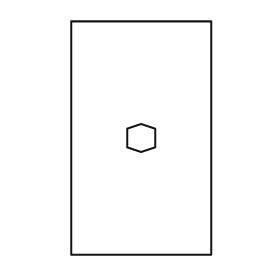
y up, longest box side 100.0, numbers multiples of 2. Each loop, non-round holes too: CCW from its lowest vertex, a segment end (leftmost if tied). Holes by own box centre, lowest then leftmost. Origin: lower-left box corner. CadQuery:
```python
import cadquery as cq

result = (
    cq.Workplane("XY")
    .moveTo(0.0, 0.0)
    .lineTo(60.0, 0.0)
    .lineTo(60.0, 100.0)
    .lineTo(0.0, 100.0)
    .close()
    .moveTo(30.0, 44.0)
    .lineTo(36.0, 46.0)
    .lineTo(36.0, 54.0)
    .lineTo(30.0, 56.0)
    .lineTo(24.0, 54.0)
    .lineTo(24.0, 46.0)
    .close()
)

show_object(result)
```